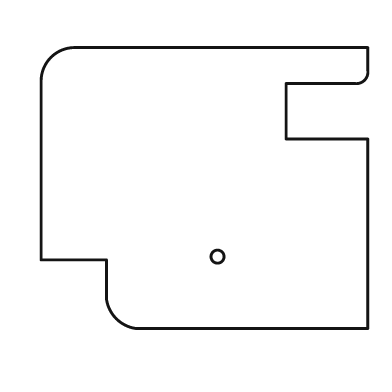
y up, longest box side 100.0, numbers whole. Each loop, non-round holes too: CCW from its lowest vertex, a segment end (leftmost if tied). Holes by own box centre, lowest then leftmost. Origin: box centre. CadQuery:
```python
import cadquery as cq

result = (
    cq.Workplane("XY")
    .moveTo(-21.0, -43.0)
    .lineTo(50.0, -43.0)
    .lineTo(50.0, 15.0)
    .lineTo(25.0, 15.0)
    .lineTo(25.0, 32.0)
    .lineTo(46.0, 32.0)
    .threePointArc((49.0, 33.0), (50.0, 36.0))
    .lineTo(50.0, 43.0)
    .lineTo(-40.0, 43.0)
    .threePointArc((-47.0, 40.0), (-50.0, 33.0))
    .lineTo(-50.0, -22.0)
    .lineTo(-30.0, -22.0)
    .lineTo(-30.0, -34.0)
    .threePointArc((-27.0, -40.0), (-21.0, -43.0))
    .close()
    .moveTo(4.0, -21.0)
    .circle(2.0)
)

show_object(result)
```